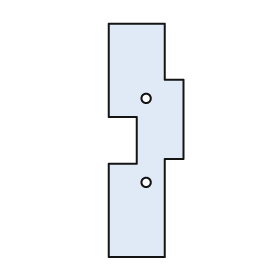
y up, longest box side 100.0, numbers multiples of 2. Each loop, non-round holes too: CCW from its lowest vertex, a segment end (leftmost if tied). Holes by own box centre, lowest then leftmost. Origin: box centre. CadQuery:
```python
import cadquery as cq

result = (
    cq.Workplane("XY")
    .moveTo(-16.0, -50.0)
    .lineTo(8.0, -50.0)
    .lineTo(8.0, -8.0)
    .lineTo(16.0, -8.0)
    .lineTo(16.0, 26.0)
    .lineTo(8.0, 26.0)
    .lineTo(8.0, 50.0)
    .lineTo(-16.0, 50.0)
    .lineTo(-16.0, 10.0)
    .lineTo(-4.0, 10.0)
    .lineTo(-4.0, -10.0)
    .lineTo(-16.0, -10.0)
    .close()
    .moveTo(0.0, -18.0)
    .circle(2.0)
    .moveTo(0.0, 18.0)
    .circle(2.0)
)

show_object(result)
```